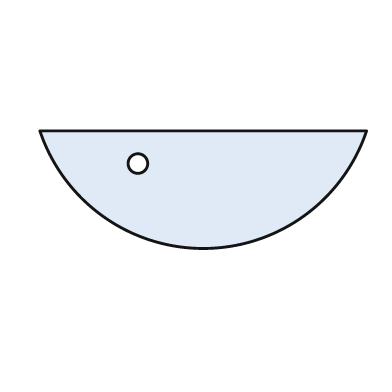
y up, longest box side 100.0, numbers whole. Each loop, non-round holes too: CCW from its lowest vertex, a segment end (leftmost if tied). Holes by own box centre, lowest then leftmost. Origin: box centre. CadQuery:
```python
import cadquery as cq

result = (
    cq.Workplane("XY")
    .moveTo(-50.0, 18.0)
    .threePointArc((0.0, -18.0), (50.0, 18.0))
    .close()
    .moveTo(-20.0, 8.0)
    .circle(3.0)
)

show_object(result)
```